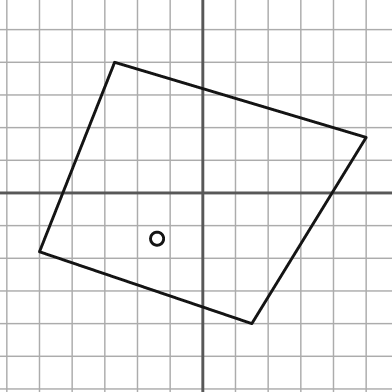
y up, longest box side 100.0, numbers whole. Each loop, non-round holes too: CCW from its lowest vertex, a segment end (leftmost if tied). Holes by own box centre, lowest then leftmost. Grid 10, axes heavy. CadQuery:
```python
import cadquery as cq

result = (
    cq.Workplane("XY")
    .moveTo(15.0, -40.0)
    .lineTo(50.0, 17.0)
    .lineTo(-27.0, 40.0)
    .lineTo(-50.0, -18.0)
    .close()
    .moveTo(-14.0, -14.0)
    .circle(2.0)
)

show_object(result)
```